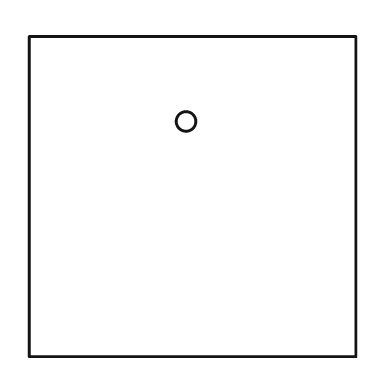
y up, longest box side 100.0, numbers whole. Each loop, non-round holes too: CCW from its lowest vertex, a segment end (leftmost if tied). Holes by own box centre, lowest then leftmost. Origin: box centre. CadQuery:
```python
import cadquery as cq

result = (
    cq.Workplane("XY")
    .moveTo(-50.0, -49.0)
    .lineTo(50.0, -49.0)
    .lineTo(50.0, 49.0)
    .lineTo(-50.0, 49.0)
    .close()
    .moveTo(-2.0, 23.0)
    .circle(3.0)
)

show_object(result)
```